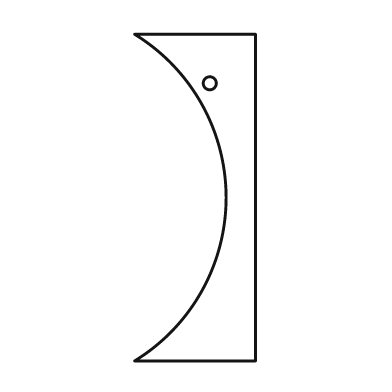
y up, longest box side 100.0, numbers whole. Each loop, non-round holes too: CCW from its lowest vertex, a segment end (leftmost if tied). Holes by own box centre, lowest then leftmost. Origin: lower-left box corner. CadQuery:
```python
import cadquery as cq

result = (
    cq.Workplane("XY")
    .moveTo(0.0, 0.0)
    .lineTo(37.0, 0.0)
    .lineTo(37.0, 100.0)
    .lineTo(0.0, 100.0)
    .threePointArc((28.0, 50.0), (0.0, 0.0))
    .close()
    .moveTo(23.0, 85.0)
    .circle(2.0)
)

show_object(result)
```